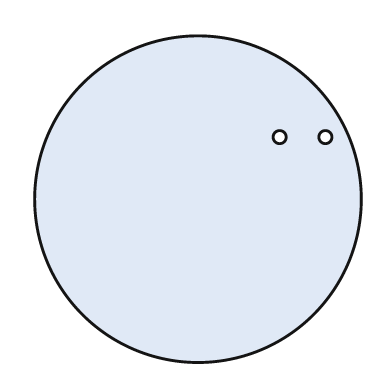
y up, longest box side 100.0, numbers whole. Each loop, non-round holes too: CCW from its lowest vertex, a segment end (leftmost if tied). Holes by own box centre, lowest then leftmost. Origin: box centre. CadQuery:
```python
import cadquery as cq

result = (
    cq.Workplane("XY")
    .moveTo(0.0, 0.0)
    .circle(50.0)
    .moveTo(25.0, 19.0)
    .circle(2.0)
    .moveTo(39.0, 19.0)
    .circle(2.0)
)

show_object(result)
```